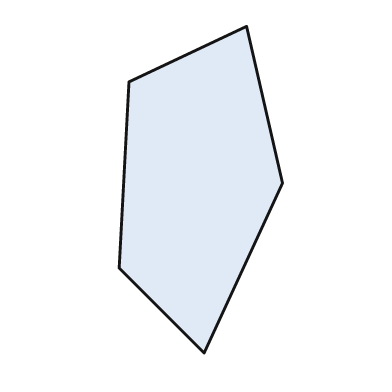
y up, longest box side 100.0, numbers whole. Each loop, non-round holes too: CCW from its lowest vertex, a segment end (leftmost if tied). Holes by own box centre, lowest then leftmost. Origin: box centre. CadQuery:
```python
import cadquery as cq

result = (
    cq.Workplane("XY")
    .moveTo(1.0, -50.0)
    .lineTo(25.0, 2.0)
    .lineTo(14.0, 50.0)
    .lineTo(-22.0, 33.0)
    .lineTo(-25.0, -24.0)
    .close()
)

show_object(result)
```